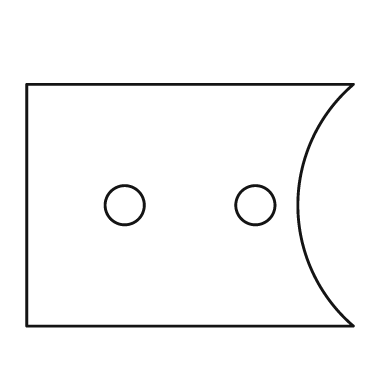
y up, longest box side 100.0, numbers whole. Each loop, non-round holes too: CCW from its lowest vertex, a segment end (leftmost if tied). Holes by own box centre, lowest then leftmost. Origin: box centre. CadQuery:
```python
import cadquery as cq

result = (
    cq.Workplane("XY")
    .moveTo(-50.0, -37.0)
    .lineTo(50.0, -37.0)
    .threePointArc((33.0, 0.0), (50.0, 37.0))
    .lineTo(-50.0, 37.0)
    .close()
    .moveTo(-20.0, 0.0)
    .circle(6.0)
    .moveTo(20.0, 0.0)
    .circle(6.0)
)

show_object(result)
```